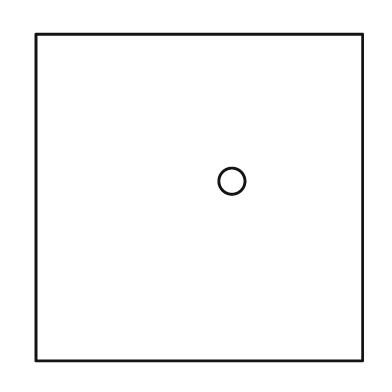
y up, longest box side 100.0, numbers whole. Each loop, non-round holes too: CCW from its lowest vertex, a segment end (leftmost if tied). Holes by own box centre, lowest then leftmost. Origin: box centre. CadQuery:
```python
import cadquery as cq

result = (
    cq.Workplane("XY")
    .moveTo(-50.0, -50.0)
    .lineTo(50.0, -50.0)
    .lineTo(50.0, 50.0)
    .lineTo(-50.0, 50.0)
    .close()
    .moveTo(10.0, 5.0)
    .circle(4.0)
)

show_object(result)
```